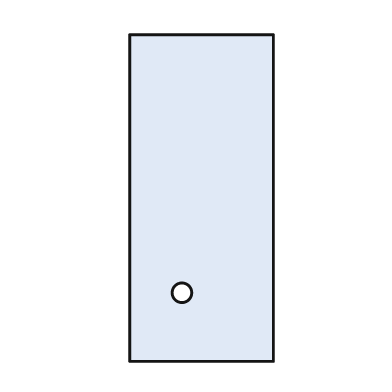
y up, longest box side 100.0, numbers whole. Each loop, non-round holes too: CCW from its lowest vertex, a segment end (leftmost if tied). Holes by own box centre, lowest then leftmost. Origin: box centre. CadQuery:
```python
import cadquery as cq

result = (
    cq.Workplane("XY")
    .moveTo(-22.0, -50.0)
    .lineTo(22.0, -50.0)
    .lineTo(22.0, 50.0)
    .lineTo(-22.0, 50.0)
    .close()
    .moveTo(-6.0, -29.0)
    .circle(3.0)
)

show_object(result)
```